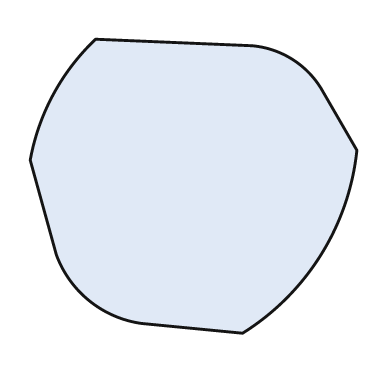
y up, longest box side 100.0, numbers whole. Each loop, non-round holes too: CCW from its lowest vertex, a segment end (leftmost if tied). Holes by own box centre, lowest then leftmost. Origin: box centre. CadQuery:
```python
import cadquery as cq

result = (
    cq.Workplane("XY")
    .moveTo(15.0, -45.0)
    .threePointArc((39.0, -21.0), (50.0, 11.0))
    .lineTo(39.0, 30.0)
    .threePointArc((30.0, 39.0), (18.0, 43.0))
    .lineTo(-30.0, 45.0)
    .threePointArc((-43.0, 28.0), (-50.0, 8.0))
    .lineTo(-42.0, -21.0)
    .threePointArc((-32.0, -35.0), (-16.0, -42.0))
    .close()
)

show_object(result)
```